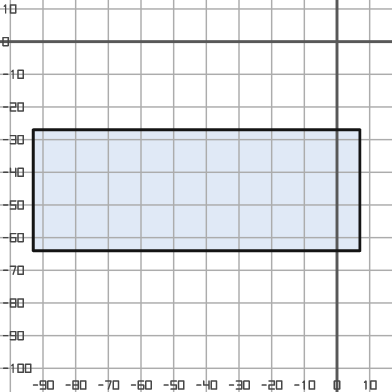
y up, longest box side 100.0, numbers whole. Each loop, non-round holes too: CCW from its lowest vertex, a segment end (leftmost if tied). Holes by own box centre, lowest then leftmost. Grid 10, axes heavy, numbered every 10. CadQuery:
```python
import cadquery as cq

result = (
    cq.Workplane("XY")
    .moveTo(-93.0, -64.0)
    .lineTo(7.0, -64.0)
    .lineTo(7.0, -27.0)
    .lineTo(-93.0, -27.0)
    .close()
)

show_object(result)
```